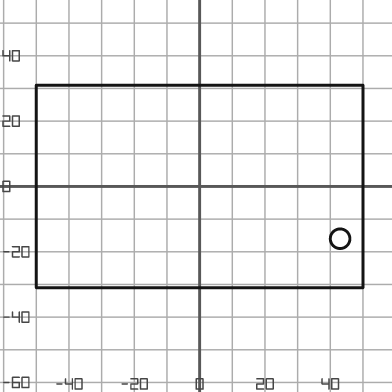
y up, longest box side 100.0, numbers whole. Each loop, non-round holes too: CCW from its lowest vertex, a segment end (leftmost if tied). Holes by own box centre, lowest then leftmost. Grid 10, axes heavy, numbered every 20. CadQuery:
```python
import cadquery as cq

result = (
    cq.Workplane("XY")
    .moveTo(-50.0, -31.0)
    .lineTo(50.0, -31.0)
    .lineTo(50.0, 31.0)
    .lineTo(-50.0, 31.0)
    .close()
    .moveTo(43.0, -16.0)
    .circle(3.0)
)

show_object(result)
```